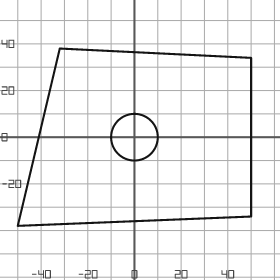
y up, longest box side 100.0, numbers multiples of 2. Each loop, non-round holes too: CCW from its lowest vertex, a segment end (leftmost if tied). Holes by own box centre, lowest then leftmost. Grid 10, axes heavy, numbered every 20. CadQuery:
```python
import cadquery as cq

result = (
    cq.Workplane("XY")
    .moveTo(-50.0, -38.0)
    .lineTo(50.0, -34.0)
    .lineTo(50.0, 34.0)
    .lineTo(-32.0, 38.0)
    .close()
    .moveTo(0.0, 0.0)
    .circle(10.0)
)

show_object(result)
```